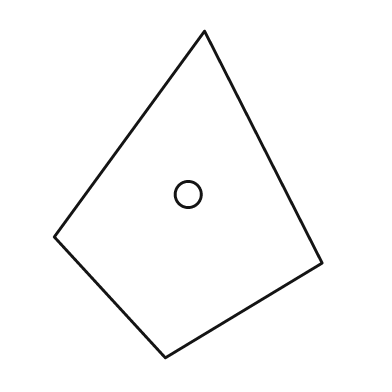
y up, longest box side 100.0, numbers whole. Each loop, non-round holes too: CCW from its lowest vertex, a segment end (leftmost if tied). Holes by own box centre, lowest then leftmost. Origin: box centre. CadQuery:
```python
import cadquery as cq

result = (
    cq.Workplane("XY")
    .moveTo(-7.0, -50.0)
    .lineTo(41.0, -21.0)
    .lineTo(5.0, 50.0)
    .lineTo(-41.0, -13.0)
    .close()
    .moveTo(0.0, 0.0)
    .circle(4.0)
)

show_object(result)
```